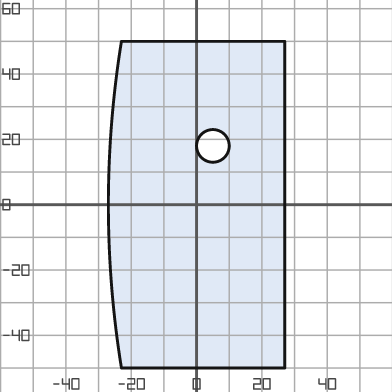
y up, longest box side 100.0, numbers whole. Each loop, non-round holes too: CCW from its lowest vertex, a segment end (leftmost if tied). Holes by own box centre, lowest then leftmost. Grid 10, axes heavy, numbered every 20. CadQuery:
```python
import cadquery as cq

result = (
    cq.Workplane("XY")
    .moveTo(-23.0, -50.0)
    .lineTo(27.0, -50.0)
    .lineTo(27.0, 50.0)
    .lineTo(-23.0, 50.0)
    .threePointArc((-27.0, 0.0), (-23.0, -50.0))
    .close()
    .moveTo(5.0, 18.0)
    .circle(5.0)
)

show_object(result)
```